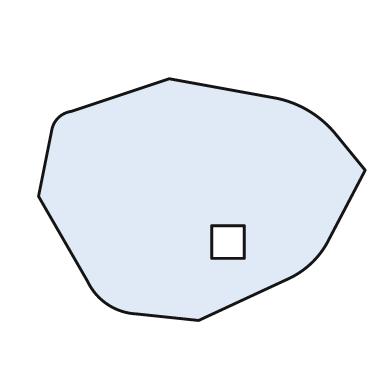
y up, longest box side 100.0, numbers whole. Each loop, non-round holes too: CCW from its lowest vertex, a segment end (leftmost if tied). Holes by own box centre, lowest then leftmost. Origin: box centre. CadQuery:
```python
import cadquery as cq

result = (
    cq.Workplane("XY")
    .moveTo(-1.0, -37.0)
    .lineTo(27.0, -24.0)
    .threePointArc((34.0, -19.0), (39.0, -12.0))
    .lineTo(50.0, 9.0)
    .lineTo(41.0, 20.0)
    .threePointArc((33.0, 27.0), (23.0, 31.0))
    .lineTo(-10.0, 37.0)
    .lineTo(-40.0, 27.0)
    .threePointArc((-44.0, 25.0), (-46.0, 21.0))
    .lineTo(-50.0, 1.0)
    .lineTo(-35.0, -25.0)
    .threePointArc((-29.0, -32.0), (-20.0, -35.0))
    .close()
    .moveTo(3.0, -18.0)
    .lineTo(13.0, -18.0)
    .lineTo(13.0, -8.0)
    .lineTo(3.0, -8.0)
    .close()
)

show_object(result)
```